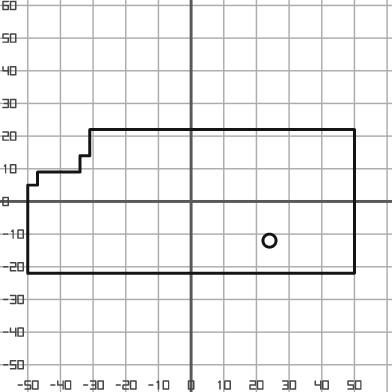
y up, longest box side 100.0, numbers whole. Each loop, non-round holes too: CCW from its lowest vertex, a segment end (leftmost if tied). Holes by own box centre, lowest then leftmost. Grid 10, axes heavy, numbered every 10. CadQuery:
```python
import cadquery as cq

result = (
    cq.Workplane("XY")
    .moveTo(-50.0, -22.0)
    .lineTo(50.0, -22.0)
    .lineTo(50.0, 22.0)
    .lineTo(-31.0, 22.0)
    .lineTo(-31.0, 14.0)
    .lineTo(-34.0, 14.0)
    .lineTo(-34.0, 9.0)
    .lineTo(-47.0, 9.0)
    .lineTo(-47.0, 5.0)
    .lineTo(-50.0, 5.0)
    .close()
    .moveTo(24.0, -12.0)
    .circle(2.0)
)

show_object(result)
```